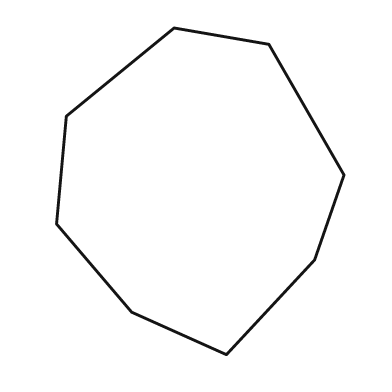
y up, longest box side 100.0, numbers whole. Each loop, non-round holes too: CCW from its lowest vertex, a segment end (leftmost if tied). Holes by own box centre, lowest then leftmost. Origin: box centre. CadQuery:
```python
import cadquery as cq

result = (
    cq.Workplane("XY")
    .moveTo(8.0, -50.0)
    .lineTo(35.0, -21.0)
    .lineTo(44.0, 5.0)
    .lineTo(21.0, 45.0)
    .lineTo(-8.0, 50.0)
    .lineTo(-41.0, 23.0)
    .lineTo(-44.0, -10.0)
    .lineTo(-21.0, -37.0)
    .close()
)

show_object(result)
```